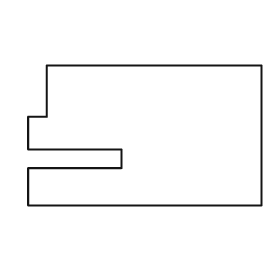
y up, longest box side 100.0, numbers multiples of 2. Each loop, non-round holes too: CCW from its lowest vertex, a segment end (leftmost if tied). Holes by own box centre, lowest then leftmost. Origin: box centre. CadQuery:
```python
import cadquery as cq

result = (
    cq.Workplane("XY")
    .moveTo(-50.0, -30.0)
    .lineTo(50.0, -30.0)
    .lineTo(50.0, 30.0)
    .lineTo(-42.0, 30.0)
    .lineTo(-42.0, 8.0)
    .lineTo(-50.0, 8.0)
    .lineTo(-50.0, -6.0)
    .lineTo(-10.0, -6.0)
    .lineTo(-10.0, -14.0)
    .lineTo(-50.0, -14.0)
    .close()
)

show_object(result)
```